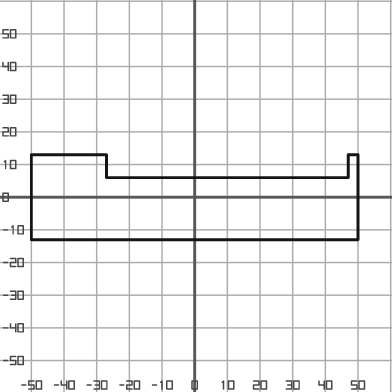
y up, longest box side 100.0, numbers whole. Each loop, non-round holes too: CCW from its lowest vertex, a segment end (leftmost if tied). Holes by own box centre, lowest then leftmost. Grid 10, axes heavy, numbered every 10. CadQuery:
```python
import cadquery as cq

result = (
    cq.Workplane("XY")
    .moveTo(-50.0, -13.0)
    .lineTo(50.0, -13.0)
    .lineTo(50.0, 13.0)
    .lineTo(47.0, 13.0)
    .lineTo(47.0, 6.0)
    .lineTo(-27.0, 6.0)
    .lineTo(-27.0, 13.0)
    .lineTo(-50.0, 13.0)
    .close()
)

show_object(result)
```